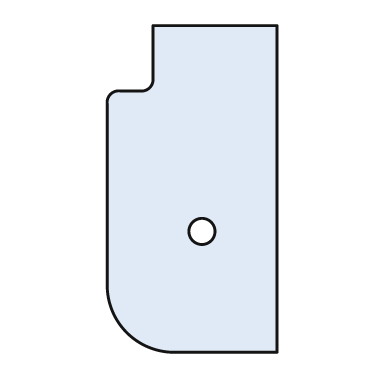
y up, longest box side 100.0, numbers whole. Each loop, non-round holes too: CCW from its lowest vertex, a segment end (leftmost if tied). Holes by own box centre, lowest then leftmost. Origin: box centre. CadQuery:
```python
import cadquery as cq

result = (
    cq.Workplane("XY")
    .moveTo(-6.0, -50.0)
    .lineTo(26.0, -50.0)
    .lineTo(26.0, 50.0)
    .lineTo(-12.0, 50.0)
    .lineTo(-12.0, 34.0)
    .threePointArc((-13.0, 31.0), (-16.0, 30.0))
    .lineTo(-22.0, 30.0)
    .threePointArc((-25.0, 29.0), (-26.0, 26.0))
    .lineTo(-26.0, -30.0)
    .threePointArc((-20.0, -44.0), (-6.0, -50.0))
    .close()
    .moveTo(3.0, -13.0)
    .circle(4.0)
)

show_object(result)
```